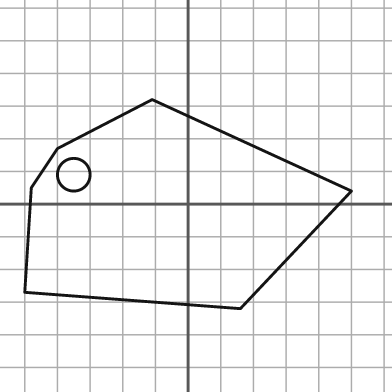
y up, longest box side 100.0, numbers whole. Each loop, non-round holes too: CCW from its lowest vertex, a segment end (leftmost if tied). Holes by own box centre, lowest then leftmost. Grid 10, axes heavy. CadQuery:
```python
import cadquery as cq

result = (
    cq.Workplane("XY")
    .moveTo(16.0, -32.0)
    .lineTo(50.0, 4.0)
    .lineTo(-11.0, 32.0)
    .lineTo(-40.0, 17.0)
    .lineTo(-48.0, 5.0)
    .lineTo(-50.0, -27.0)
    .close()
    .moveTo(-35.0, 9.0)
    .circle(5.0)
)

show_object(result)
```